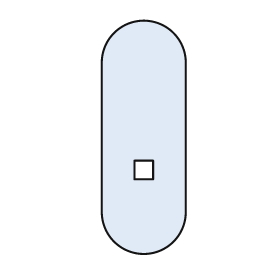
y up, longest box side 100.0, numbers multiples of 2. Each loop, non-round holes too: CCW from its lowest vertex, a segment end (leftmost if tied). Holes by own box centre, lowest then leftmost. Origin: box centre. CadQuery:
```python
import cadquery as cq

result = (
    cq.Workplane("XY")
    .moveTo(-18.0, -32.0)
    .threePointArc((0.0, -50.0), (18.0, -32.0))
    .lineTo(18.0, 32.0)
    .threePointArc((0.0, 50.0), (-18.0, 32.0))
    .close()
    .moveTo(-4.0, -18.0)
    .lineTo(4.0, -18.0)
    .lineTo(4.0, -10.0)
    .lineTo(-4.0, -10.0)
    .close()
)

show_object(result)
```